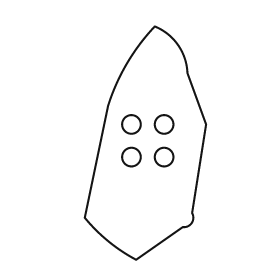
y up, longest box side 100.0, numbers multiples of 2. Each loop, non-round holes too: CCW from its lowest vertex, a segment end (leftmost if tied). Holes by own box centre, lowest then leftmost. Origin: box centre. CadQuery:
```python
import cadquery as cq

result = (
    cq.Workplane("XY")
    .moveTo(-4.0, -50.0)
    .lineTo(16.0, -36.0)
    .threePointArc((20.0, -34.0), (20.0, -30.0))
    .lineTo(26.0, 8.0)
    .lineTo(18.0, 30.0)
    .threePointArc((14.0, 42.0), (4.0, 50.0))
    .threePointArc((-8.0, 34.0), (-16.0, 16.0))
    .lineTo(-26.0, -32.0)
    .threePointArc((-16.0, -42.0), (-4.0, -50.0))
    .close()
    .moveTo(-6.0, -6.0)
    .circle(4.0)
    .moveTo(8.0, -6.0)
    .circle(4.0)
    .moveTo(-6.0, 8.0)
    .circle(4.0)
    .moveTo(8.0, 8.0)
    .circle(4.0)
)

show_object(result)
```